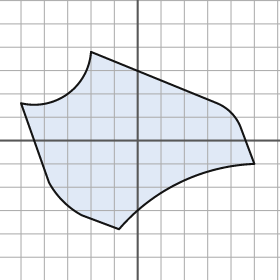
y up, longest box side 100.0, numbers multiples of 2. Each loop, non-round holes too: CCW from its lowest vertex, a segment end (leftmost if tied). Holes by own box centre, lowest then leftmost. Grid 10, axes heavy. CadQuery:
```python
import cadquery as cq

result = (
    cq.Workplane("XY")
    .moveTo(-8.0, -38.0)
    .threePointArc((18.0, -18.0), (50.0, -10.0))
    .lineTo(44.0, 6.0)
    .threePointArc((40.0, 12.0), (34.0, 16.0))
    .lineTo(-20.0, 38.0)
    .threePointArc((-30.0, 20.0), (-50.0, 16.0))
    .lineTo(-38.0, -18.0)
    .threePointArc((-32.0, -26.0), (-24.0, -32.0))
    .close()
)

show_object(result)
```